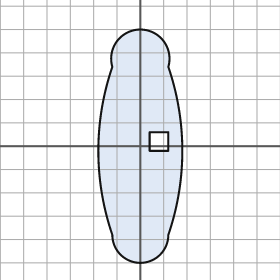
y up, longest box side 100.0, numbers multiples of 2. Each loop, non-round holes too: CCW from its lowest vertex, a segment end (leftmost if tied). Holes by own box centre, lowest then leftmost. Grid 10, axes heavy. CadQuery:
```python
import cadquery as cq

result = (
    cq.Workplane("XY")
    .moveTo(-12.0, -38.0)
    .threePointArc((0.0, -50.0), (12.0, -38.0))
    .threePointArc((18.0, -2.0), (12.0, 34.0))
    .threePointArc((0.0, 50.0), (-12.0, 34.0))
    .threePointArc((-18.0, -2.0), (-12.0, -38.0))
    .close()
    .moveTo(4.0, -2.0)
    .lineTo(12.0, -2.0)
    .lineTo(12.0, 6.0)
    .lineTo(4.0, 6.0)
    .close()
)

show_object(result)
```